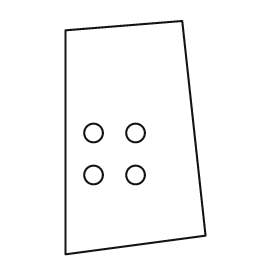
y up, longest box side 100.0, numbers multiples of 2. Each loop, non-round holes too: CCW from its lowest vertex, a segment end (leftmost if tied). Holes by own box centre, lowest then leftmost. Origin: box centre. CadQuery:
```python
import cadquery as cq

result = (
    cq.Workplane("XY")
    .moveTo(-30.0, -50.0)
    .lineTo(30.0, -42.0)
    .lineTo(20.0, 50.0)
    .lineTo(-30.0, 46.0)
    .close()
    .moveTo(-18.0, -16.0)
    .circle(4.0)
    .moveTo(0.0, -16.0)
    .circle(4.0)
    .moveTo(-18.0, 2.0)
    .circle(4.0)
    .moveTo(0.0, 2.0)
    .circle(4.0)
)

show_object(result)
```